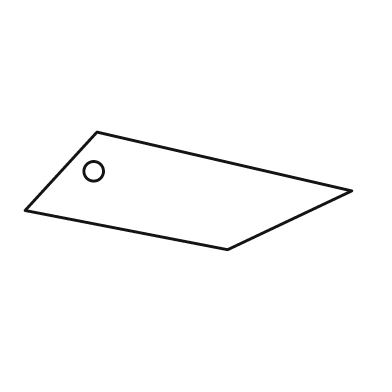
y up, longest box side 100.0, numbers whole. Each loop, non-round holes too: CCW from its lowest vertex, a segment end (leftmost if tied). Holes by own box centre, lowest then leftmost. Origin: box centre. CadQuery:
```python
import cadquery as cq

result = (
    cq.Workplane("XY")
    .moveTo(12.0, -18.0)
    .lineTo(50.0, 0.0)
    .lineTo(-28.0, 18.0)
    .lineTo(-50.0, -6.0)
    .close()
    .moveTo(-29.0, 6.0)
    .circle(3.0)
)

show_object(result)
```